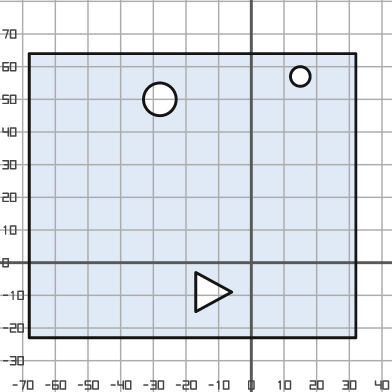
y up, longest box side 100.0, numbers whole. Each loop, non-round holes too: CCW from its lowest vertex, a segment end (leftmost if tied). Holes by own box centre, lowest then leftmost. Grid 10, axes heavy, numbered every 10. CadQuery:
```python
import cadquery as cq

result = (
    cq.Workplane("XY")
    .moveTo(-68.0, -23.0)
    .lineTo(32.0, -23.0)
    .lineTo(32.0, 64.0)
    .lineTo(-68.0, 64.0)
    .close()
    .moveTo(-17.0, -15.0)
    .lineTo(-6.0, -9.0)
    .lineTo(-17.0, -3.0)
    .close()
    .moveTo(-28.0, 50.0)
    .circle(5.0)
    .moveTo(15.0, 57.0)
    .circle(3.0)
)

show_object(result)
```